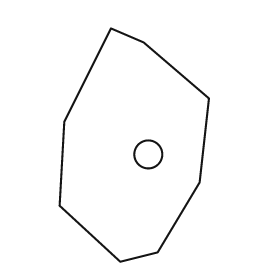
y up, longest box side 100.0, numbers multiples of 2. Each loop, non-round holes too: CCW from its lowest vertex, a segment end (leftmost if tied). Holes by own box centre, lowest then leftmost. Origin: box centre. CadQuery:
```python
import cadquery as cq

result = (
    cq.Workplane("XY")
    .moveTo(-6.0, -50.0)
    .lineTo(10.0, -46.0)
    .lineTo(28.0, -16.0)
    .lineTo(32.0, 20.0)
    .lineTo(4.0, 44.0)
    .lineTo(-10.0, 50.0)
    .lineTo(-30.0, 10.0)
    .lineTo(-32.0, -26.0)
    .close()
    .moveTo(6.0, -4.0)
    .circle(6.0)
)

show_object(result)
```